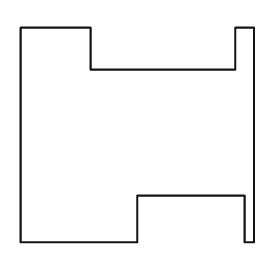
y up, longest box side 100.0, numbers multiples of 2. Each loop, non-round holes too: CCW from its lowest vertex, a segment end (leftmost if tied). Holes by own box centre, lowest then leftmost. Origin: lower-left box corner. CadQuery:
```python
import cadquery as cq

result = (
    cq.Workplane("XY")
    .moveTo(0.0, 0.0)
    .lineTo(50.0, 0.0)
    .lineTo(50.0, 20.0)
    .lineTo(96.0, 20.0)
    .lineTo(96.0, 0.0)
    .lineTo(100.0, 0.0)
    .lineTo(100.0, 92.0)
    .lineTo(92.0, 92.0)
    .lineTo(92.0, 74.0)
    .lineTo(30.0, 74.0)
    .lineTo(30.0, 92.0)
    .lineTo(0.0, 92.0)
    .close()
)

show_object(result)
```